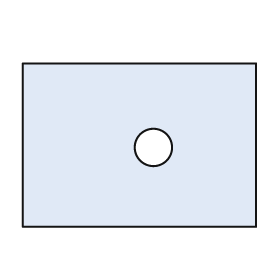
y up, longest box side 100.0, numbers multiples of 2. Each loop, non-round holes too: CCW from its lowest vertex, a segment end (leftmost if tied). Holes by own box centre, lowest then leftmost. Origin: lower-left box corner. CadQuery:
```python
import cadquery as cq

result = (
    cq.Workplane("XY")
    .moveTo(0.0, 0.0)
    .lineTo(100.0, 0.0)
    .lineTo(100.0, 70.0)
    .lineTo(0.0, 70.0)
    .close()
    .moveTo(56.0, 34.0)
    .circle(8.0)
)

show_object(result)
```